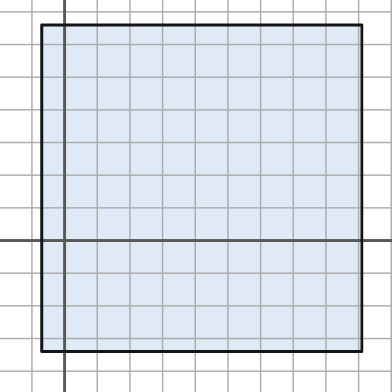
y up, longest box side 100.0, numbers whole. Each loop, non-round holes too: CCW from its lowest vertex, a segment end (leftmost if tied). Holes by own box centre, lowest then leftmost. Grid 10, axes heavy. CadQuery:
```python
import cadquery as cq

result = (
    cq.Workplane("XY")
    .moveTo(-7.0, -34.0)
    .lineTo(91.0, -34.0)
    .lineTo(91.0, 66.0)
    .lineTo(-7.0, 66.0)
    .close()
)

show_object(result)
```